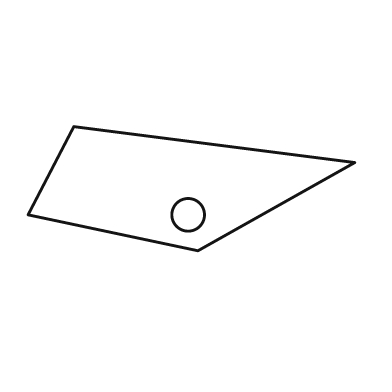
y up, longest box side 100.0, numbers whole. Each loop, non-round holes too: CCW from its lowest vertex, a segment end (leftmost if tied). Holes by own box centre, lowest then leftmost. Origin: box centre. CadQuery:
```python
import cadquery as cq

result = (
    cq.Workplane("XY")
    .moveTo(2.0, -19.0)
    .lineTo(50.0, 8.0)
    .lineTo(-36.0, 19.0)
    .lineTo(-50.0, -8.0)
    .close()
    .moveTo(-1.0, -8.0)
    .circle(5.0)
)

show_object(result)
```